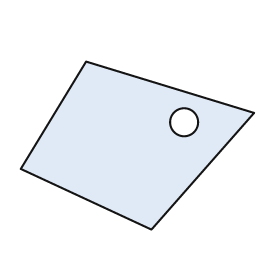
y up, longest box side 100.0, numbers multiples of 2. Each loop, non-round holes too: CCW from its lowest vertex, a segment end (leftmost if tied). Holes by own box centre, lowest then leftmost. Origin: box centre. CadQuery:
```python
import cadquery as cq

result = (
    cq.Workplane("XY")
    .moveTo(6.0, -36.0)
    .lineTo(50.0, 14.0)
    .lineTo(-22.0, 36.0)
    .lineTo(-50.0, -10.0)
    .close()
    .moveTo(20.0, 10.0)
    .circle(6.0)
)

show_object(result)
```